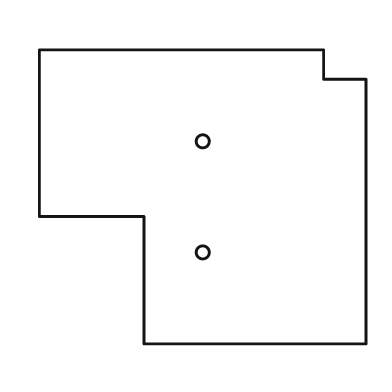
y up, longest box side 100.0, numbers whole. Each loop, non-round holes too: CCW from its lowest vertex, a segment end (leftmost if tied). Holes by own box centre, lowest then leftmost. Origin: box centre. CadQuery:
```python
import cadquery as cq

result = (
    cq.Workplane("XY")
    .moveTo(-18.0, -45.0)
    .lineTo(50.0, -45.0)
    .lineTo(50.0, 36.0)
    .lineTo(37.0, 36.0)
    .lineTo(37.0, 45.0)
    .lineTo(-50.0, 45.0)
    .lineTo(-50.0, -6.0)
    .lineTo(-18.0, -6.0)
    .close()
    .moveTo(0.0, -17.0)
    .circle(2.0)
    .moveTo(0.0, 17.0)
    .circle(2.0)
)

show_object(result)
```